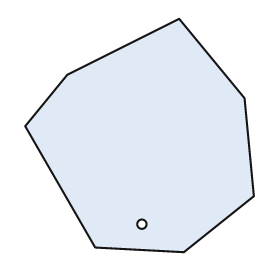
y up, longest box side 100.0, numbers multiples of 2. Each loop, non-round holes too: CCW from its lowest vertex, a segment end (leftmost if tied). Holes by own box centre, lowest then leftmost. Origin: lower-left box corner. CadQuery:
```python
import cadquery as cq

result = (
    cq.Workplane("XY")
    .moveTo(68.0, 0.0)
    .lineTo(98.0, 24.0)
    .lineTo(94.0, 66.0)
    .lineTo(66.0, 100.0)
    .lineTo(18.0, 76.0)
    .lineTo(0.0, 54.0)
    .lineTo(30.0, 2.0)
    .close()
    .moveTo(50.0, 12.0)
    .circle(2.0)
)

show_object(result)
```